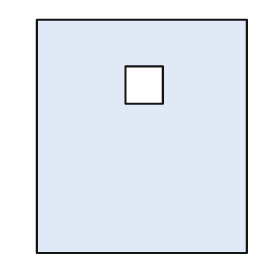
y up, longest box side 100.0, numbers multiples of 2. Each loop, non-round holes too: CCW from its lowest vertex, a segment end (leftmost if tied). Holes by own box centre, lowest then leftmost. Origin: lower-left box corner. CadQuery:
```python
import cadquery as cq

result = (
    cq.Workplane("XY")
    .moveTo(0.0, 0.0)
    .lineTo(90.0, 0.0)
    .lineTo(90.0, 100.0)
    .lineTo(0.0, 100.0)
    .close()
    .moveTo(38.0, 64.0)
    .lineTo(54.0, 64.0)
    .lineTo(54.0, 80.0)
    .lineTo(38.0, 80.0)
    .close()
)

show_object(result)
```